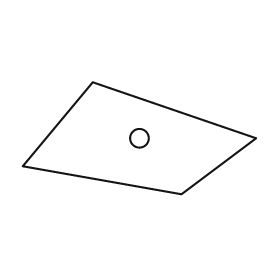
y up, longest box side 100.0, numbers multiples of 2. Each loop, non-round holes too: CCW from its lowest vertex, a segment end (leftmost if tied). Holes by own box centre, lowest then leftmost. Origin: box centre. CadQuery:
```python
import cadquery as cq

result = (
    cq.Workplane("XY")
    .moveTo(18.0, -24.0)
    .lineTo(50.0, 0.0)
    .lineTo(-20.0, 24.0)
    .lineTo(-50.0, -12.0)
    .close()
    .moveTo(0.0, 0.0)
    .circle(4.0)
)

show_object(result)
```